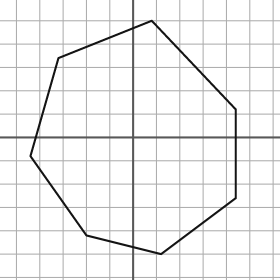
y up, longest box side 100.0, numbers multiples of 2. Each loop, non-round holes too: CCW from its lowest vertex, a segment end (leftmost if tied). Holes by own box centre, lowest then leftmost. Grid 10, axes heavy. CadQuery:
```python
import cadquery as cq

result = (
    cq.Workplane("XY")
    .moveTo(12.0, -50.0)
    .lineTo(44.0, -26.0)
    .lineTo(44.0, 12.0)
    .lineTo(8.0, 50.0)
    .lineTo(-32.0, 34.0)
    .lineTo(-44.0, -8.0)
    .lineTo(-20.0, -42.0)
    .close()
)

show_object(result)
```